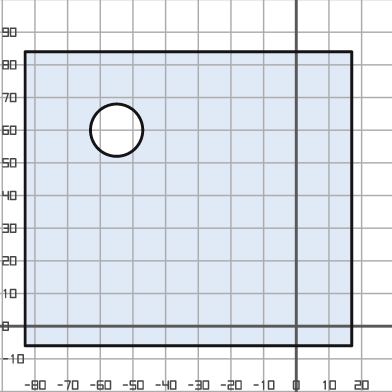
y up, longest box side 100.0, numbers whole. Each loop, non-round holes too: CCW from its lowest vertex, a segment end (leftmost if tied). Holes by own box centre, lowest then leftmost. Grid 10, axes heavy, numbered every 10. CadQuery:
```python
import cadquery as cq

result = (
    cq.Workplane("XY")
    .moveTo(-83.0, -6.0)
    .lineTo(17.0, -6.0)
    .lineTo(17.0, 84.0)
    .lineTo(-83.0, 84.0)
    .close()
    .moveTo(-55.0, 60.0)
    .circle(8.0)
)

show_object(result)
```